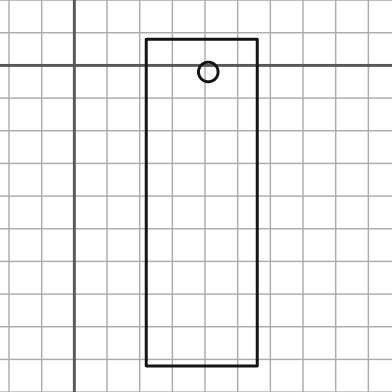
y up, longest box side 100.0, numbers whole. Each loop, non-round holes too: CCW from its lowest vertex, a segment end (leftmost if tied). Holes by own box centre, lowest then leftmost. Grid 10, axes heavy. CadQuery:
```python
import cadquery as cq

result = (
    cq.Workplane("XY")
    .moveTo(22.0, -92.0)
    .lineTo(56.0, -92.0)
    .lineTo(56.0, 8.0)
    .lineTo(22.0, 8.0)
    .close()
    .moveTo(41.0, -2.0)
    .circle(3.0)
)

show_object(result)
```